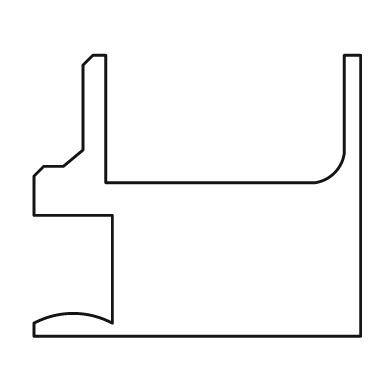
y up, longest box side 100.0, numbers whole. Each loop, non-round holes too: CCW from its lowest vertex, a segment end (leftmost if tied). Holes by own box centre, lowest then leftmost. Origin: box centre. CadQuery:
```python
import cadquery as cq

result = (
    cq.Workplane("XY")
    .moveTo(-50.0, -43.0)
    .lineTo(50.0, -43.0)
    .lineTo(50.0, 43.0)
    .lineTo(45.0, 43.0)
    .lineTo(45.0, 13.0)
    .threePointArc((42.0, 7.0), (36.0, 4.0))
    .lineTo(-28.0, 4.0)
    .lineTo(-28.0, 43.0)
    .lineTo(-32.0, 43.0)
    .lineTo(-35.0, 40.0)
    .lineTo(-35.0, 14.0)
    .lineTo(-41.0, 9.0)
    .lineTo(-47.0, 9.0)
    .lineTo(-50.0, 6.0)
    .lineTo(-50.0, -6.0)
    .lineTo(-26.0, -6.0)
    .lineTo(-26.0, -39.0)
    .threePointArc((-38.0, -36.0), (-50.0, -39.0))
    .close()
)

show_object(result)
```